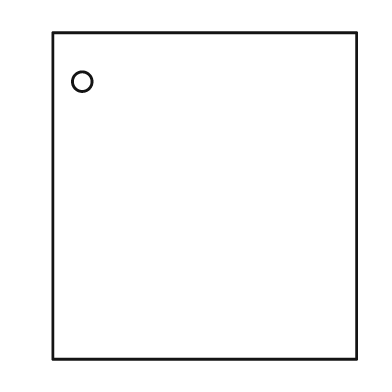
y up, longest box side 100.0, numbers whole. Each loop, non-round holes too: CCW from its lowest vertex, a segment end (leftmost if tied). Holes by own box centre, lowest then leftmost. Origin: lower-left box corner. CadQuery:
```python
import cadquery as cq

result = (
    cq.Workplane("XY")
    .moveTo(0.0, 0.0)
    .lineTo(93.0, 0.0)
    .lineTo(93.0, 100.0)
    .lineTo(0.0, 100.0)
    .close()
    .moveTo(9.0, 85.0)
    .circle(3.0)
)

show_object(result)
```